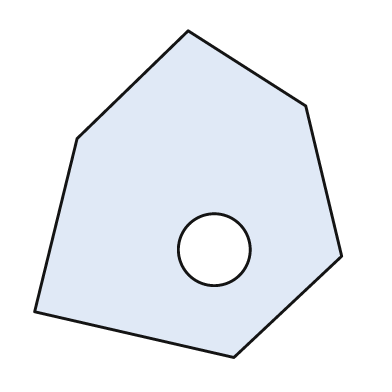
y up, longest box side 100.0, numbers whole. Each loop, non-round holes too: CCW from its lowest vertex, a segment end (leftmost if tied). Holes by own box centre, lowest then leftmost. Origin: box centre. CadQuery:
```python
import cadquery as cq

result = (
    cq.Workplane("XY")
    .moveTo(14.0, -50.0)
    .lineTo(47.0, -19.0)
    .lineTo(36.0, 27.0)
    .lineTo(0.0, 50.0)
    .lineTo(-34.0, 17.0)
    .lineTo(-47.0, -36.0)
    .close()
    .moveTo(8.0, -17.0)
    .circle(11.0)
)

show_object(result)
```